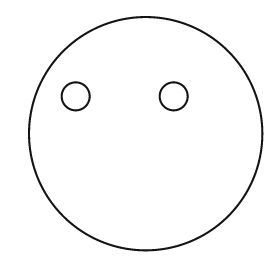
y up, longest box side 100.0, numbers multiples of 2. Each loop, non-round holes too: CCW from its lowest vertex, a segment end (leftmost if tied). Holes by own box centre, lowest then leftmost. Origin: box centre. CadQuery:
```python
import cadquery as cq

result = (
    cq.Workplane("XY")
    .moveTo(0.0, 0.0)
    .circle(50.0)
    .moveTo(-30.0, 16.0)
    .circle(6.0)
    .moveTo(12.0, 16.0)
    .circle(6.0)
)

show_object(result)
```